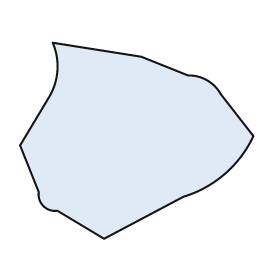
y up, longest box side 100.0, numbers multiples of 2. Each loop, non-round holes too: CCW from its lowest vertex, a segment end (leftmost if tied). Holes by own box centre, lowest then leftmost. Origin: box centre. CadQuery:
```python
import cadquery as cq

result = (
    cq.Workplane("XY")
    .moveTo(-14.0, -42.0)
    .lineTo(20.0, -24.0)
    .threePointArc((38.0, -14.0), (50.0, 2.0))
    .lineTo(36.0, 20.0)
    .threePointArc((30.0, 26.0), (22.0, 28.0))
    .lineTo(2.0, 36.0)
    .lineTo(-36.0, 42.0)
    .threePointArc((-34.0, 30.0), (-38.0, 18.0))
    .lineTo(-50.0, -2.0)
    .lineTo(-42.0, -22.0)
    .threePointArc((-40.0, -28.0), (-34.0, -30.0))
    .close()
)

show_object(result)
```